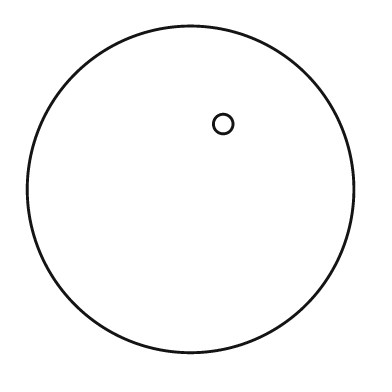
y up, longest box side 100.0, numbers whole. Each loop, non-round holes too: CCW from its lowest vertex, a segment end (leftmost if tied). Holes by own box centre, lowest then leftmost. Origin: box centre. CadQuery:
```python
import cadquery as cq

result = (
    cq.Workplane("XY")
    .moveTo(0.0, 0.0)
    .circle(50.0)
    .moveTo(10.0, 20.0)
    .circle(3.0)
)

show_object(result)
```